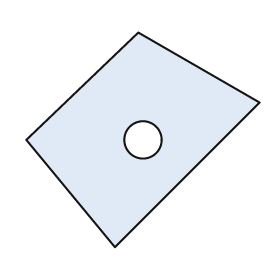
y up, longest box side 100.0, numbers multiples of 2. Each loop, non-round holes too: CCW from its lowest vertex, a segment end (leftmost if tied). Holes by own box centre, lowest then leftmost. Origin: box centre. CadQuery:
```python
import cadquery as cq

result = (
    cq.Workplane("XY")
    .moveTo(-12.0, -46.0)
    .lineTo(50.0, 16.0)
    .lineTo(-2.0, 46.0)
    .lineTo(-50.0, 0.0)
    .close()
    .moveTo(0.0, 0.0)
    .circle(8.0)
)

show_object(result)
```